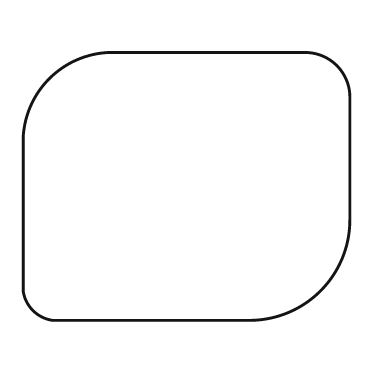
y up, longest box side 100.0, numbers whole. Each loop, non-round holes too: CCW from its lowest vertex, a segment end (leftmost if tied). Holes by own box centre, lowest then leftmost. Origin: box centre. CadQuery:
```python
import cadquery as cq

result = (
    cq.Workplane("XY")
    .moveTo(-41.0, -41.0)
    .lineTo(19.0, -41.0)
    .threePointArc((41.0, -32.0), (50.0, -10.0))
    .lineTo(50.0, 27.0)
    .threePointArc((46.0, 37.0), (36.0, 41.0))
    .lineTo(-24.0, 41.0)
    .threePointArc((-42.0, 33.0), (-50.0, 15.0))
    .lineTo(-50.0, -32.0)
    .threePointArc((-47.0, -38.0), (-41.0, -41.0))
    .close()
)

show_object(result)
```